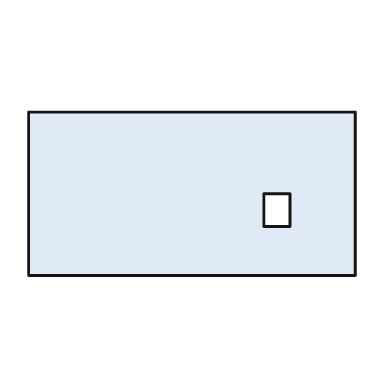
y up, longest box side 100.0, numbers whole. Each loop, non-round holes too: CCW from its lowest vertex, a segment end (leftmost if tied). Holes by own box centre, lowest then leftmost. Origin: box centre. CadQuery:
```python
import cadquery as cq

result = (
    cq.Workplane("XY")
    .moveTo(-50.0, -25.0)
    .lineTo(50.0, -25.0)
    .lineTo(50.0, 25.0)
    .lineTo(-50.0, 25.0)
    .close()
    .moveTo(22.0, -10.0)
    .lineTo(30.0, -10.0)
    .lineTo(30.0, 0.0)
    .lineTo(22.0, 0.0)
    .close()
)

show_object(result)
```